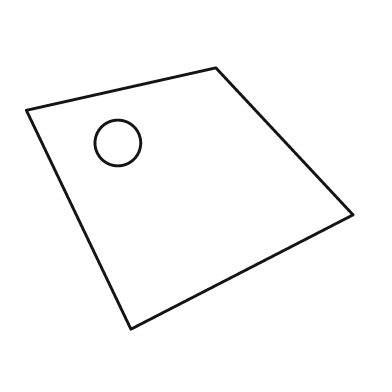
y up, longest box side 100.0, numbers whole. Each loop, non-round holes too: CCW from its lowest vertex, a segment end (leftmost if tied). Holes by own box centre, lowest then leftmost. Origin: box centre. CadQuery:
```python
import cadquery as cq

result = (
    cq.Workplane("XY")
    .moveTo(-18.0, -40.0)
    .lineTo(50.0, -5.0)
    .lineTo(8.0, 40.0)
    .lineTo(-50.0, 27.0)
    .close()
    .moveTo(-22.0, 17.0)
    .circle(7.0)
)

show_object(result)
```